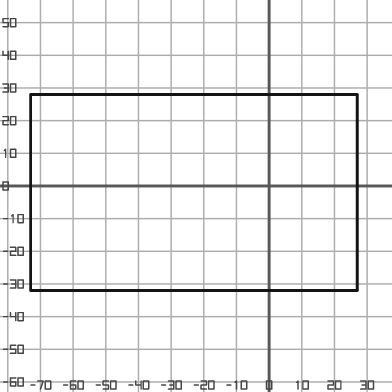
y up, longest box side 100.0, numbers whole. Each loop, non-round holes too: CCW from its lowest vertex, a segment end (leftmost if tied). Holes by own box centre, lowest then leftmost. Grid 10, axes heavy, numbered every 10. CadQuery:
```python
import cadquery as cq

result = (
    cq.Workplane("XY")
    .moveTo(-73.0, -32.0)
    .lineTo(27.0, -32.0)
    .lineTo(27.0, 28.0)
    .lineTo(-73.0, 28.0)
    .close()
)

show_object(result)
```